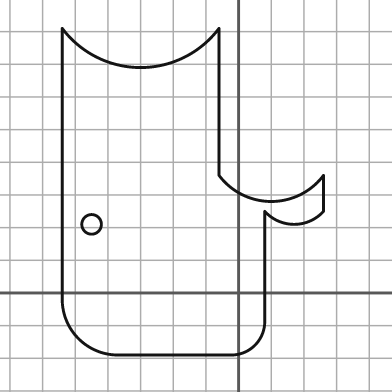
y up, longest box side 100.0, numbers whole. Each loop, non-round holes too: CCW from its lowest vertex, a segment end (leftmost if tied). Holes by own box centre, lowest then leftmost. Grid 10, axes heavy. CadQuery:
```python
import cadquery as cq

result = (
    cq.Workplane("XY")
    .moveTo(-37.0, -19.0)
    .lineTo(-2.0, -19.0)
    .threePointArc((5.0, -16.0), (8.0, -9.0))
    .lineTo(8.0, 25.0)
    .threePointArc((17.0, 21.0), (26.0, 25.0))
    .lineTo(26.0, 36.0)
    .threePointArc((10.0, 28.0), (-6.0, 36.0))
    .lineTo(-6.0, 81.0)
    .threePointArc((-30.0, 69.0), (-54.0, 81.0))
    .lineTo(-54.0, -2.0)
    .threePointArc((-49.0, -14.0), (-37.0, -19.0))
    .close()
    .moveTo(-45.0, 21.0)
    .circle(3.0)
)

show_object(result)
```